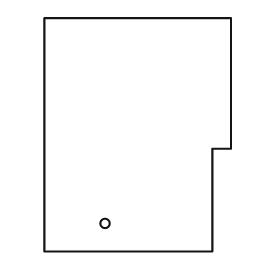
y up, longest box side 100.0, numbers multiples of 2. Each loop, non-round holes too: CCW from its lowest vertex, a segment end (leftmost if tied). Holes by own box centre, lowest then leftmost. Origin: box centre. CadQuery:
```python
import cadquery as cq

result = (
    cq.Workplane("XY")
    .moveTo(-40.0, -50.0)
    .lineTo(32.0, -50.0)
    .lineTo(32.0, -6.0)
    .lineTo(40.0, -6.0)
    .lineTo(40.0, 50.0)
    .lineTo(-40.0, 50.0)
    .close()
    .moveTo(-14.0, -38.0)
    .circle(2.0)
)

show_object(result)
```